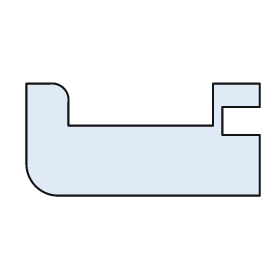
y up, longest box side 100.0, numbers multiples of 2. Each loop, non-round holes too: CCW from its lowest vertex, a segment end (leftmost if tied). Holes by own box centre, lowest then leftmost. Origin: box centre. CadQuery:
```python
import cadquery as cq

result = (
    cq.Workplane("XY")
    .moveTo(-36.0, -24.0)
    .lineTo(50.0, -24.0)
    .lineTo(50.0, 2.0)
    .lineTo(34.0, 2.0)
    .lineTo(34.0, 14.0)
    .lineTo(50.0, 14.0)
    .lineTo(50.0, 24.0)
    .lineTo(30.0, 24.0)
    .lineTo(30.0, 6.0)
    .lineTo(-32.0, 6.0)
    .lineTo(-32.0, 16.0)
    .threePointArc((-34.0, 22.0), (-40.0, 24.0))
    .lineTo(-50.0, 24.0)
    .lineTo(-50.0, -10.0)
    .threePointArc((-46.0, -20.0), (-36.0, -24.0))
    .close()
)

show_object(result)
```